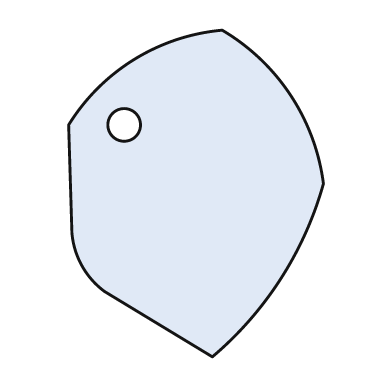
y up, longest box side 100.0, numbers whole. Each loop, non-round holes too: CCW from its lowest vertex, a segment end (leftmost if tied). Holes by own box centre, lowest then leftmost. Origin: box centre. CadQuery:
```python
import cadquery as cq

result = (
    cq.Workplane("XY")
    .moveTo(5.0, -50.0)
    .threePointArc((26.0, -26.0), (39.0, 3.0))
    .threePointArc((29.0, 30.0), (8.0, 50.0))
    .threePointArc((-19.0, 41.0), (-39.0, 21.0))
    .lineTo(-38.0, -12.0)
    .threePointArc((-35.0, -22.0), (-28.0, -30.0))
    .close()
    .moveTo(-22.0, 21.0)
    .circle(5.0)
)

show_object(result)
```